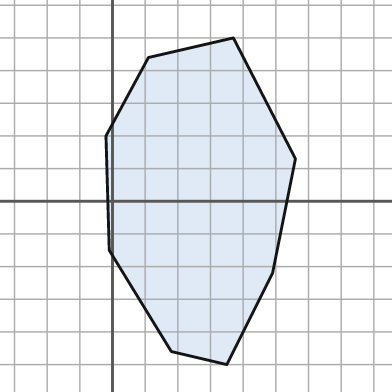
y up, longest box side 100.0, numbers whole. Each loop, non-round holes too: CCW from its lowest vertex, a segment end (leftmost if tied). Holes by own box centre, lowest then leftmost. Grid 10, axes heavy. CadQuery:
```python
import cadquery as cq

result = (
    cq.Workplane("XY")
    .moveTo(35.0, -50.0)
    .lineTo(49.0, -22.0)
    .lineTo(56.0, 13.0)
    .lineTo(37.0, 50.0)
    .lineTo(11.0, 44.0)
    .lineTo(-2.0, 20.0)
    .lineTo(-1.0, -15.0)
    .lineTo(18.0, -46.0)
    .close()
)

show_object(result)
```